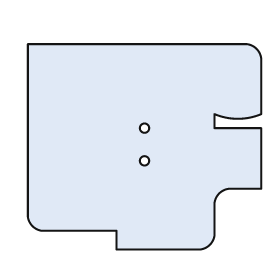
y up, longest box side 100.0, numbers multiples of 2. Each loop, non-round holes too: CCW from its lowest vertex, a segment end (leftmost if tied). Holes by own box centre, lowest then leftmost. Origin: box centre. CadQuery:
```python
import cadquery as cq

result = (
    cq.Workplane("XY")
    .moveTo(-12.0, -44.0)
    .lineTo(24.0, -44.0)
    .threePointArc((28.0, -42.0), (30.0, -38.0))
    .lineTo(30.0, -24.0)
    .threePointArc((32.0, -20.0), (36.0, -18.0))
    .lineTo(50.0, -18.0)
    .lineTo(50.0, 8.0)
    .lineTo(30.0, 8.0)
    .lineTo(30.0, 14.0)
    .threePointArc((40.0, 12.0), (50.0, 14.0))
    .lineTo(50.0, 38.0)
    .threePointArc((48.0, 42.0), (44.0, 44.0))
    .lineTo(-50.0, 44.0)
    .lineTo(-50.0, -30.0)
    .threePointArc((-48.0, -34.0), (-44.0, -36.0))
    .lineTo(-12.0, -36.0)
    .close()
    .moveTo(0.0, -6.0)
    .circle(2.0)
    .moveTo(0.0, 8.0)
    .circle(2.0)
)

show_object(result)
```